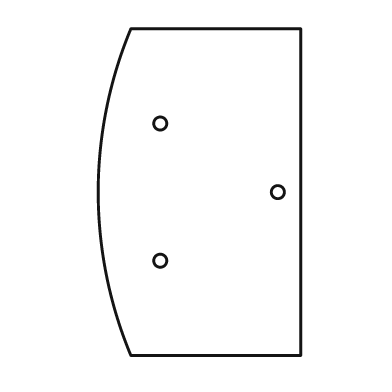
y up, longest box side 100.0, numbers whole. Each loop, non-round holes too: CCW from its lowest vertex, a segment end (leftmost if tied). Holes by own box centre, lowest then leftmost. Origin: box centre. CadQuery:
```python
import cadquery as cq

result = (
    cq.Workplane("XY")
    .moveTo(-21.0, -50.0)
    .lineTo(31.0, -50.0)
    .lineTo(31.0, 50.0)
    .lineTo(-21.0, 50.0)
    .threePointArc((-31.0, 0.0), (-21.0, -50.0))
    .close()
    .moveTo(-12.0, -21.0)
    .circle(2.0)
    .moveTo(24.0, 0.0)
    .circle(2.0)
    .moveTo(-12.0, 21.0)
    .circle(2.0)
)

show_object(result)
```